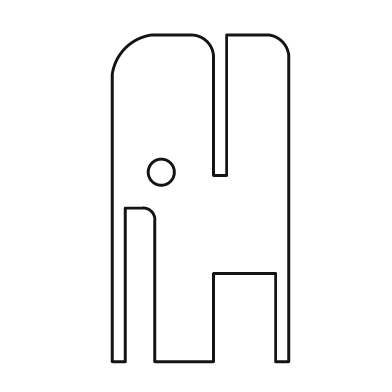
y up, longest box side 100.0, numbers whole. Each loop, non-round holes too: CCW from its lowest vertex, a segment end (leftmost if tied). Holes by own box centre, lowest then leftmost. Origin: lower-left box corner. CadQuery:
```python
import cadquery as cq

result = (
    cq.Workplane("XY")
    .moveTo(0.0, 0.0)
    .lineTo(4.0, 0.0)
    .lineTo(4.0, 47.0)
    .lineTo(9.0, 47.0)
    .threePointArc((12.0, 46.0), (13.0, 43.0))
    .lineTo(13.0, 0.0)
    .lineTo(31.0, 0.0)
    .lineTo(31.0, 27.0)
    .lineTo(50.0, 27.0)
    .lineTo(50.0, 0.0)
    .lineTo(54.0, 0.0)
    .lineTo(54.0, 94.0)
    .threePointArc((52.0, 98.0), (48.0, 100.0))
    .lineTo(35.0, 100.0)
    .lineTo(35.0, 57.0)
    .lineTo(31.0, 57.0)
    .lineTo(31.0, 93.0)
    .threePointArc((29.0, 98.0), (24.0, 100.0))
    .lineTo(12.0, 100.0)
    .threePointArc((4.0, 96.0), (0.0, 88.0))
    .close()
    .moveTo(15.0, 58.0)
    .circle(4.0)
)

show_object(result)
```